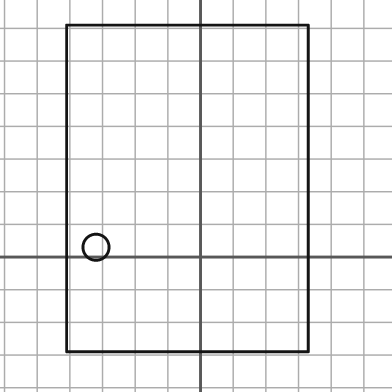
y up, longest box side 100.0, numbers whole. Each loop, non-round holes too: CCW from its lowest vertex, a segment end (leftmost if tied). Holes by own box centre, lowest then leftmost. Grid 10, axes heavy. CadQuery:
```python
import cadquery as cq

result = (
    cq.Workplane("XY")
    .moveTo(-41.0, -29.0)
    .lineTo(33.0, -29.0)
    .lineTo(33.0, 71.0)
    .lineTo(-41.0, 71.0)
    .close()
    .moveTo(-32.0, 3.0)
    .circle(4.0)
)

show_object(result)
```